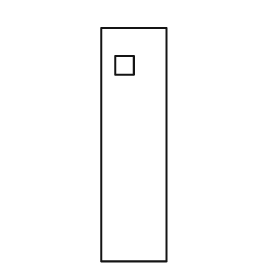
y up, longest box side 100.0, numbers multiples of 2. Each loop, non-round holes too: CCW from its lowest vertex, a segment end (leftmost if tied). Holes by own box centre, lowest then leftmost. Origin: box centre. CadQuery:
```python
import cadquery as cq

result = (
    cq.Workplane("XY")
    .moveTo(-14.0, -50.0)
    .lineTo(14.0, -50.0)
    .lineTo(14.0, 50.0)
    .lineTo(-14.0, 50.0)
    .close()
    .moveTo(-8.0, 30.0)
    .lineTo(0.0, 30.0)
    .lineTo(0.0, 38.0)
    .lineTo(-8.0, 38.0)
    .close()
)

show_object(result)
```